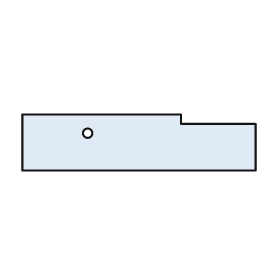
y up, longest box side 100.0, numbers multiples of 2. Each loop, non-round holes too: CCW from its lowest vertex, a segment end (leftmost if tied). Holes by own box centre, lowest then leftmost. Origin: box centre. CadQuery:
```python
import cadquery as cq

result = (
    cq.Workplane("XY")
    .moveTo(-50.0, -12.0)
    .lineTo(50.0, -12.0)
    .lineTo(50.0, 8.0)
    .lineTo(18.0, 8.0)
    .lineTo(18.0, 12.0)
    .lineTo(-50.0, 12.0)
    .close()
    .moveTo(-22.0, 4.0)
    .circle(2.0)
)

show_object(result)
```